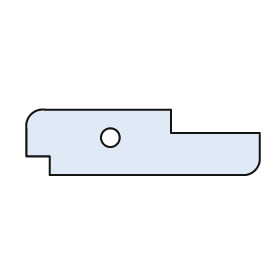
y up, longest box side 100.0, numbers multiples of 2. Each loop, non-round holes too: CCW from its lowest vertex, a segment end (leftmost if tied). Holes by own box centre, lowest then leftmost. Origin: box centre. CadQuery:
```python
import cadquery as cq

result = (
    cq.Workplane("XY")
    .moveTo(-40.0, -14.0)
    .lineTo(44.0, -14.0)
    .threePointArc((48.0, -12.0), (50.0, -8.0))
    .lineTo(50.0, 4.0)
    .lineTo(12.0, 4.0)
    .lineTo(12.0, 14.0)
    .lineTo(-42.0, 14.0)
    .threePointArc((-48.0, 12.0), (-50.0, 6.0))
    .lineTo(-50.0, -6.0)
    .lineTo(-40.0, -6.0)
    .close()
    .moveTo(-14.0, 2.0)
    .circle(4.0)
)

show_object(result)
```